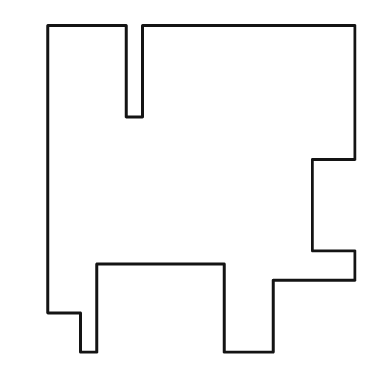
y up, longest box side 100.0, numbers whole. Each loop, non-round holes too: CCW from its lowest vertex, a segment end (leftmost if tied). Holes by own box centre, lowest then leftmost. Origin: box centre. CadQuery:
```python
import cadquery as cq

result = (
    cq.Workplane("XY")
    .moveTo(-37.0, -50.0)
    .lineTo(-32.0, -50.0)
    .lineTo(-32.0, -23.0)
    .lineTo(7.0, -23.0)
    .lineTo(7.0, -50.0)
    .lineTo(22.0, -50.0)
    .lineTo(22.0, -28.0)
    .lineTo(47.0, -28.0)
    .lineTo(47.0, -19.0)
    .lineTo(34.0, -19.0)
    .lineTo(34.0, 9.0)
    .lineTo(47.0, 9.0)
    .lineTo(47.0, 50.0)
    .lineTo(-18.0, 50.0)
    .lineTo(-18.0, 22.0)
    .lineTo(-23.0, 22.0)
    .lineTo(-23.0, 50.0)
    .lineTo(-47.0, 50.0)
    .lineTo(-47.0, -38.0)
    .lineTo(-37.0, -38.0)
    .close()
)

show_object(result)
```